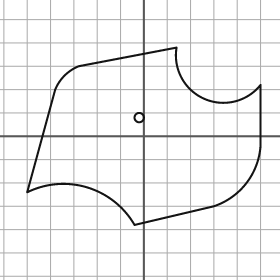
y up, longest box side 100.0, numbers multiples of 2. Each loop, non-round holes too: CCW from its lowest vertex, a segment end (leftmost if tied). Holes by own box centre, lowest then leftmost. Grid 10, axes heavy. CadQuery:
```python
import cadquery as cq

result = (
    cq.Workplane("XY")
    .moveTo(-4.0, -38.0)
    .lineTo(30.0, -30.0)
    .threePointArc((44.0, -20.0), (50.0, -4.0))
    .lineTo(50.0, 22.0)
    .threePointArc((26.0, 16.0), (14.0, 38.0))
    .lineTo(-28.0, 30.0)
    .threePointArc((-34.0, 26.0), (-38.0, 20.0))
    .lineTo(-50.0, -24.0)
    .threePointArc((-24.0, -22.0), (-4.0, -38.0))
    .close()
    .moveTo(-2.0, 8.0)
    .circle(2.0)
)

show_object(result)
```